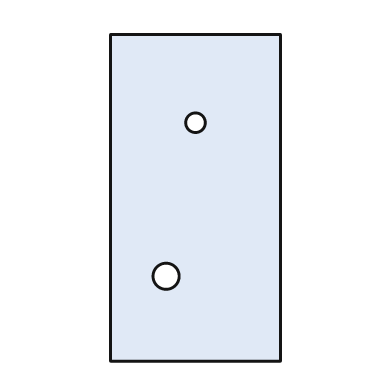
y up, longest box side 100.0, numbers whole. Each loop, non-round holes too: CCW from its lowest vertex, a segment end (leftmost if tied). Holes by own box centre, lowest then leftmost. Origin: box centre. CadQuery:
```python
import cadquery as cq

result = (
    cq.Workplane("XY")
    .moveTo(-26.0, -50.0)
    .lineTo(26.0, -50.0)
    .lineTo(26.0, 50.0)
    .lineTo(-26.0, 50.0)
    .close()
    .moveTo(-9.0, -24.0)
    .circle(4.0)
    .moveTo(0.0, 23.0)
    .circle(3.0)
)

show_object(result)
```